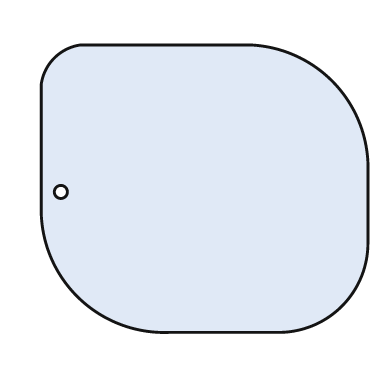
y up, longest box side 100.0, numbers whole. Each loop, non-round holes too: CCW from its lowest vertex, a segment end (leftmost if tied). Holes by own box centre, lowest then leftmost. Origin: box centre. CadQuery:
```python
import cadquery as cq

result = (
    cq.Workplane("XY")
    .moveTo(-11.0, -44.0)
    .lineTo(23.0, -44.0)
    .threePointArc((42.0, -36.0), (50.0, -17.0))
    .lineTo(50.0, 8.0)
    .threePointArc((39.0, 33.0), (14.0, 44.0))
    .lineTo(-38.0, 44.0)
    .threePointArc((-46.0, 40.0), (-50.0, 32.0))
    .lineTo(-50.0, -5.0)
    .threePointArc((-39.0, -33.0), (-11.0, -44.0))
    .close()
    .moveTo(-44.0, -1.0)
    .circle(2.0)
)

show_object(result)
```